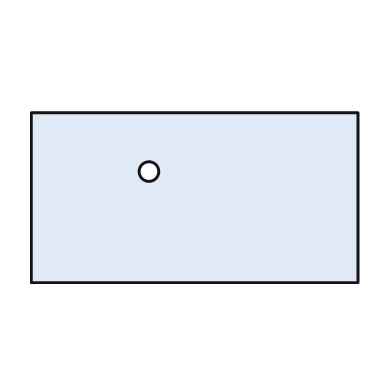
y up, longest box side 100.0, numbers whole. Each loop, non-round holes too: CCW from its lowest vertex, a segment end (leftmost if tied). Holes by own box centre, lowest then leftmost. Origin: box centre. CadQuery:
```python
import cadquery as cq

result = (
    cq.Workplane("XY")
    .moveTo(-50.0, -26.0)
    .lineTo(50.0, -26.0)
    .lineTo(50.0, 26.0)
    .lineTo(-50.0, 26.0)
    .close()
    .moveTo(-14.0, 8.0)
    .circle(3.0)
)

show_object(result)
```